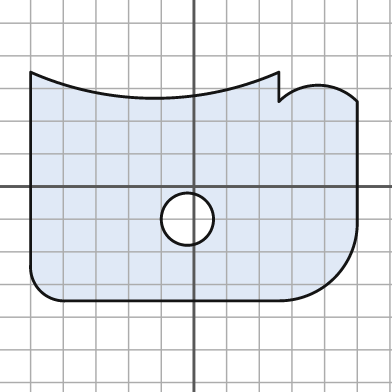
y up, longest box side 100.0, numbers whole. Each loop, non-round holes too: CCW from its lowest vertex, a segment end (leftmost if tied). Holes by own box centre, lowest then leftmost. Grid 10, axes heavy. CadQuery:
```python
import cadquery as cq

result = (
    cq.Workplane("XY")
    .moveTo(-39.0, -35.0)
    .lineTo(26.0, -35.0)
    .threePointArc((43.0, -28.0), (50.0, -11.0))
    .lineTo(50.0, 26.0)
    .threePointArc((38.0, 31.0), (26.0, 26.0))
    .lineTo(26.0, 35.0)
    .threePointArc((-12.0, 27.0), (-50.0, 35.0))
    .lineTo(-50.0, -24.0)
    .threePointArc((-47.0, -32.0), (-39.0, -35.0))
    .close()
    .moveTo(-2.0, -10.0)
    .circle(8.0)
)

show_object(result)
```